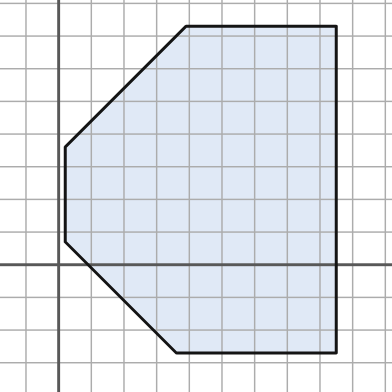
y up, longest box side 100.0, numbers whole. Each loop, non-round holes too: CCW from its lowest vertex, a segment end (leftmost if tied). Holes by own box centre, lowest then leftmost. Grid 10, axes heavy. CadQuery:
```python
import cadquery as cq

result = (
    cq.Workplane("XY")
    .moveTo(36.0, -27.0)
    .lineTo(85.0, -27.0)
    .lineTo(85.0, 73.0)
    .lineTo(39.0, 73.0)
    .lineTo(2.0, 36.0)
    .lineTo(2.0, 7.0)
    .close()
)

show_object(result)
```